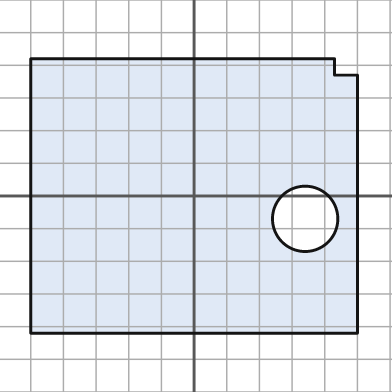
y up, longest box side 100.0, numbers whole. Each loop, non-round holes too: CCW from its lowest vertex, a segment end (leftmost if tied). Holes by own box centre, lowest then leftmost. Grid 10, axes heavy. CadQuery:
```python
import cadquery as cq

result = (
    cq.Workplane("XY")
    .moveTo(-50.0, -42.0)
    .lineTo(50.0, -42.0)
    .lineTo(50.0, 37.0)
    .lineTo(43.0, 37.0)
    .lineTo(43.0, 42.0)
    .lineTo(-50.0, 42.0)
    .close()
    .moveTo(34.0, -7.0)
    .circle(10.0)
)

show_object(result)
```